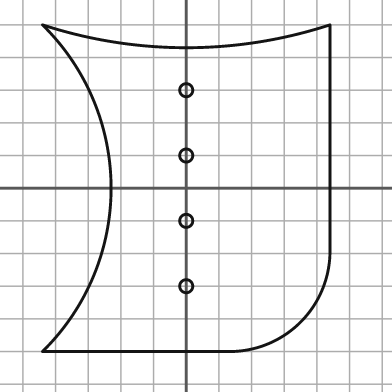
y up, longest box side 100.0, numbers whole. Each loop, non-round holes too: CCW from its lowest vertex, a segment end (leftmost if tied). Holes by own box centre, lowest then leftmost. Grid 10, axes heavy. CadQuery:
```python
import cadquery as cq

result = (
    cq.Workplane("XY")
    .moveTo(-44.0, -50.0)
    .lineTo(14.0, -50.0)
    .threePointArc((35.0, -41.0), (44.0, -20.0))
    .lineTo(44.0, 50.0)
    .threePointArc((0.0, 43.0), (-44.0, 50.0))
    .threePointArc((-23.0, 0.0), (-44.0, -50.0))
    .close()
    .moveTo(0.0, -30.0)
    .circle(2.0)
    .moveTo(0.0, -10.0)
    .circle(2.0)
    .moveTo(0.0, 10.0)
    .circle(2.0)
    .moveTo(0.0, 30.0)
    .circle(2.0)
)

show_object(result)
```